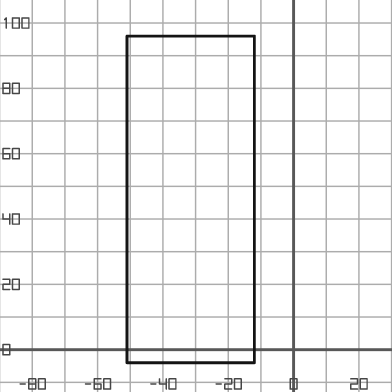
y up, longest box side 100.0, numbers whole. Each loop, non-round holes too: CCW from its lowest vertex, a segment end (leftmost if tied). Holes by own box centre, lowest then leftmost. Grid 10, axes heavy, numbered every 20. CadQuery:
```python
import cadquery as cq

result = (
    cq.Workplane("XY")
    .moveTo(-51.0, -4.0)
    .lineTo(-12.0, -4.0)
    .lineTo(-12.0, 96.0)
    .lineTo(-51.0, 96.0)
    .close()
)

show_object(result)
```